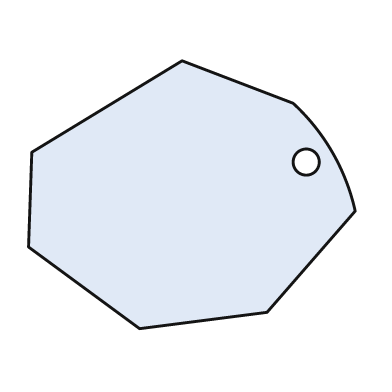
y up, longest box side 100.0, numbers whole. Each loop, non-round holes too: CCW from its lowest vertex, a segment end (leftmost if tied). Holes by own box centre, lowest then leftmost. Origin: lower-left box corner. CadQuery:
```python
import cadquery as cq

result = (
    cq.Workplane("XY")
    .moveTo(34.0, 0.0)
    .lineTo(73.0, 5.0)
    .lineTo(100.0, 36.0)
    .threePointArc((93.0, 54.0), (81.0, 69.0))
    .lineTo(47.0, 82.0)
    .lineTo(1.0, 54.0)
    .lineTo(0.0, 25.0)
    .close()
    .moveTo(85.0, 51.0)
    .circle(4.0)
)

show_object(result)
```